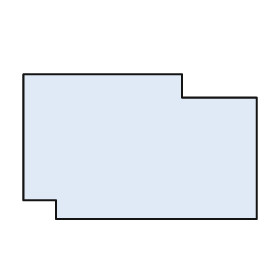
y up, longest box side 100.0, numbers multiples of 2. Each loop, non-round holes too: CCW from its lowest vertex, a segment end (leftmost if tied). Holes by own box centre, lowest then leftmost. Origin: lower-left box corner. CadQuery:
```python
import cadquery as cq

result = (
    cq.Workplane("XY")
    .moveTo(14.0, 0.0)
    .lineTo(100.0, 0.0)
    .lineTo(100.0, 52.0)
    .lineTo(68.0, 52.0)
    .lineTo(68.0, 62.0)
    .lineTo(0.0, 62.0)
    .lineTo(0.0, 8.0)
    .lineTo(14.0, 8.0)
    .close()
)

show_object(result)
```